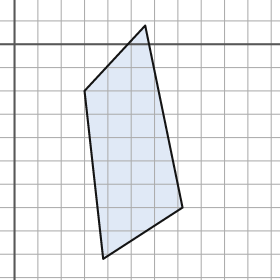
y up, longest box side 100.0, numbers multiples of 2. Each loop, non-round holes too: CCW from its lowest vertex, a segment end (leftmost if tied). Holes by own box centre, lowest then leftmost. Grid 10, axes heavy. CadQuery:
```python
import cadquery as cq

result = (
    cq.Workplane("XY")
    .moveTo(38.0, -92.0)
    .lineTo(72.0, -70.0)
    .lineTo(56.0, 8.0)
    .lineTo(30.0, -20.0)
    .close()
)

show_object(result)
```